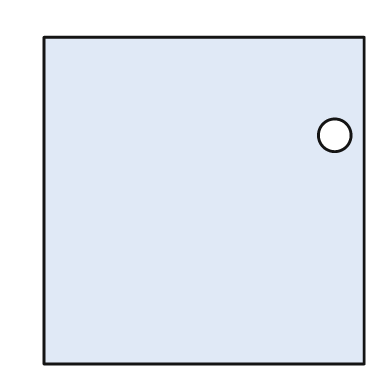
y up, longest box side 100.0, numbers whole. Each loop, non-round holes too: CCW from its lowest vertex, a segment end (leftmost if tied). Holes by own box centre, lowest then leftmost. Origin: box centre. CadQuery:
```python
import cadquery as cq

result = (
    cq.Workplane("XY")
    .moveTo(-49.0, -50.0)
    .lineTo(49.0, -50.0)
    .lineTo(49.0, 50.0)
    .lineTo(-49.0, 50.0)
    .close()
    .moveTo(40.0, 20.0)
    .circle(5.0)
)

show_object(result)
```